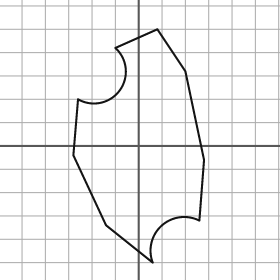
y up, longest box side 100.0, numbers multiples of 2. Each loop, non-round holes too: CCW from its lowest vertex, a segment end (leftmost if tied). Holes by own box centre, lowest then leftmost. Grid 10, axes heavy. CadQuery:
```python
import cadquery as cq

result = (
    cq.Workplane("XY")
    .moveTo(6.0, -50.0)
    .threePointArc((10.0, -34.0), (26.0, -32.0))
    .lineTo(28.0, -6.0)
    .lineTo(20.0, 32.0)
    .lineTo(8.0, 50.0)
    .lineTo(-10.0, 42.0)
    .threePointArc((-8.0, 24.0), (-26.0, 20.0))
    .lineTo(-28.0, -4.0)
    .lineTo(-14.0, -34.0)
    .close()
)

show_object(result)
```